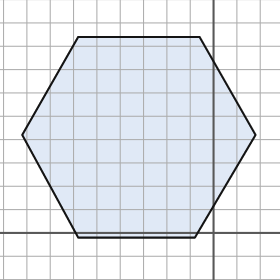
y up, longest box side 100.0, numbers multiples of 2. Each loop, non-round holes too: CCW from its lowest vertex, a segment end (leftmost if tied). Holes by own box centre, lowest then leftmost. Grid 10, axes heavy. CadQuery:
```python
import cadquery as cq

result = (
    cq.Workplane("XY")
    .moveTo(-58.0, -2.0)
    .lineTo(-8.0, -2.0)
    .lineTo(18.0, 42.0)
    .lineTo(-6.0, 84.0)
    .lineTo(-58.0, 84.0)
    .lineTo(-82.0, 42.0)
    .close()
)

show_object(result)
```